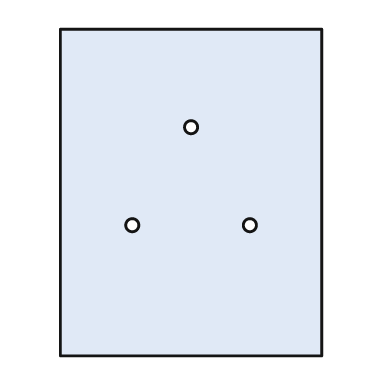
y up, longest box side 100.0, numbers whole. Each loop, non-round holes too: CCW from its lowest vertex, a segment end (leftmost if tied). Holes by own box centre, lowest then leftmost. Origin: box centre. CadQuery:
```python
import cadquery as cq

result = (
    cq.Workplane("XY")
    .moveTo(-40.0, -50.0)
    .lineTo(40.0, -50.0)
    .lineTo(40.0, 50.0)
    .lineTo(-40.0, 50.0)
    .close()
    .moveTo(-18.0, -10.0)
    .circle(2.0)
    .moveTo(18.0, -10.0)
    .circle(2.0)
    .moveTo(0.0, 20.0)
    .circle(2.0)
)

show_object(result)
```